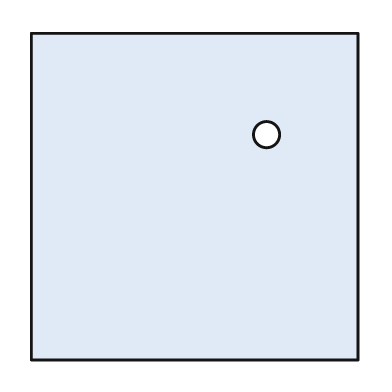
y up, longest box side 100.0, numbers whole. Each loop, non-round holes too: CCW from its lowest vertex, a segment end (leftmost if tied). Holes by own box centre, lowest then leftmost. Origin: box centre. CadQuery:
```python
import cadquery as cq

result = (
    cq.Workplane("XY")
    .moveTo(-50.0, -50.0)
    .lineTo(50.0, -50.0)
    .lineTo(50.0, 50.0)
    .lineTo(-50.0, 50.0)
    .close()
    .moveTo(22.0, 19.0)
    .circle(4.0)
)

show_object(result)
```